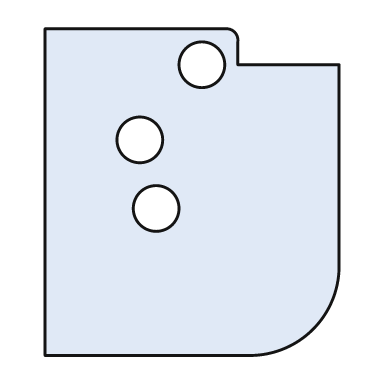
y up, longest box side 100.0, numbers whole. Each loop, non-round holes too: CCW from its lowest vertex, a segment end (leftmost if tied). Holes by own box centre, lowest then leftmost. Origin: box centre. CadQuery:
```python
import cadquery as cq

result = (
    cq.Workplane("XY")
    .moveTo(-45.0, -50.0)
    .lineTo(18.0, -50.0)
    .threePointArc((37.0, -42.0), (45.0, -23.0))
    .lineTo(45.0, 39.0)
    .lineTo(14.0, 39.0)
    .lineTo(14.0, 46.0)
    .threePointArc((13.0, 49.0), (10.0, 50.0))
    .lineTo(-45.0, 50.0)
    .close()
    .moveTo(-11.0, -5.0)
    .circle(7.0)
    .moveTo(-16.0, 16.0)
    .circle(7.0)
    .moveTo(3.0, 39.0)
    .circle(7.0)
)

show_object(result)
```